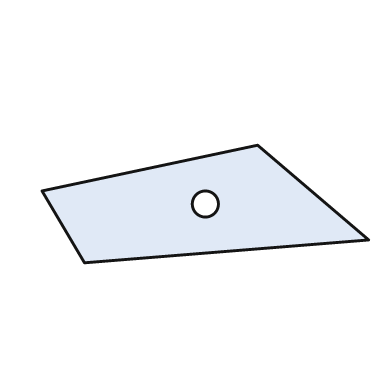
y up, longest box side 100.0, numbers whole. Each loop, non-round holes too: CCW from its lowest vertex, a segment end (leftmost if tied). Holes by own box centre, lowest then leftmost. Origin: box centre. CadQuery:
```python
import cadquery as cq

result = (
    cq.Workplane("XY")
    .moveTo(-37.0, -18.0)
    .lineTo(50.0, -11.0)
    .lineTo(16.0, 18.0)
    .lineTo(-50.0, 4.0)
    .close()
    .moveTo(0.0, 0.0)
    .circle(4.0)
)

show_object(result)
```